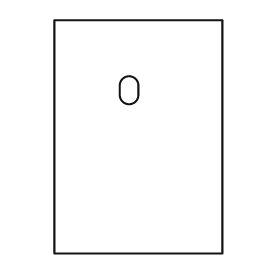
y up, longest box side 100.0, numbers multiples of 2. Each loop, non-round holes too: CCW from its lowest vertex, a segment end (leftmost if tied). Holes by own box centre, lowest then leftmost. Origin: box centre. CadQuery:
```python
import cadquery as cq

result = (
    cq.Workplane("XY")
    .moveTo(-36.0, -50.0)
    .lineTo(36.0, -50.0)
    .lineTo(36.0, 50.0)
    .lineTo(-36.0, 50.0)
    .close()
    .moveTo(-8.0, 18.0)
    .threePointArc((-4.0, 14.0), (0.0, 18.0))
    .lineTo(0.0, 22.0)
    .threePointArc((-4.0, 26.0), (-8.0, 22.0))
    .close()
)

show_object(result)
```